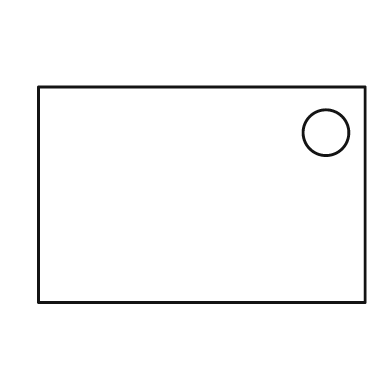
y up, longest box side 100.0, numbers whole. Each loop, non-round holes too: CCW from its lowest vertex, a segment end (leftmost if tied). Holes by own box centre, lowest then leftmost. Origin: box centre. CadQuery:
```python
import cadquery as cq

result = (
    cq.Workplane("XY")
    .moveTo(-50.0, -33.0)
    .lineTo(50.0, -33.0)
    .lineTo(50.0, 33.0)
    .lineTo(-50.0, 33.0)
    .close()
    .moveTo(38.0, 19.0)
    .circle(7.0)
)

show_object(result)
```